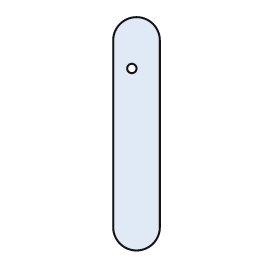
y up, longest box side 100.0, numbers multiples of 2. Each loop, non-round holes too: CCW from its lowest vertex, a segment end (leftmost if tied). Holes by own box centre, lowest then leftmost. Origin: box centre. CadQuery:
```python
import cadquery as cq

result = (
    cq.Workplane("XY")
    .moveTo(-10.0, -40.0)
    .threePointArc((0.0, -50.0), (10.0, -40.0))
    .lineTo(10.0, 40.0)
    .threePointArc((0.0, 50.0), (-10.0, 40.0))
    .close()
    .moveTo(-2.0, 28.0)
    .circle(2.0)
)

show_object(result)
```